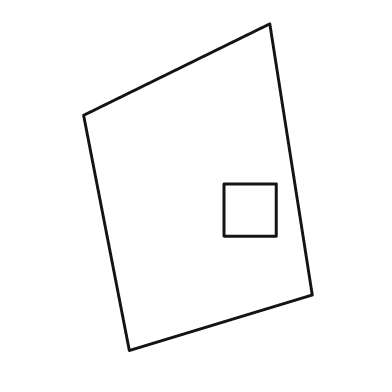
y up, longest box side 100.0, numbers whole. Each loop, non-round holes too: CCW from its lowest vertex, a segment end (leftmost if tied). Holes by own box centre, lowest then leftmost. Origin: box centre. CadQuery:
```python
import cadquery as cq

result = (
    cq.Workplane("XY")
    .moveTo(-21.0, -50.0)
    .lineTo(35.0, -33.0)
    .lineTo(22.0, 50.0)
    .lineTo(-35.0, 22.0)
    .close()
    .moveTo(8.0, -15.0)
    .lineTo(24.0, -15.0)
    .lineTo(24.0, 1.0)
    .lineTo(8.0, 1.0)
    .close()
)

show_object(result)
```